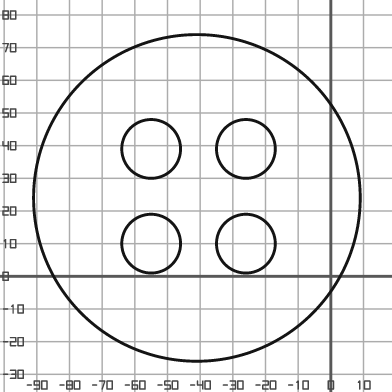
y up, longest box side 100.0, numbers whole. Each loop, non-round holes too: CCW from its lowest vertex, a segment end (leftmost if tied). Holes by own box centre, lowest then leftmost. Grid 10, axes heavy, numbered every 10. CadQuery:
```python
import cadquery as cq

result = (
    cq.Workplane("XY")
    .moveTo(-41.0, 24.0)
    .circle(50.0)
    .moveTo(-55.0, 10.0)
    .circle(9.0)
    .moveTo(-26.0, 10.0)
    .circle(9.0)
    .moveTo(-55.0, 39.0)
    .circle(9.0)
    .moveTo(-26.0, 39.0)
    .circle(9.0)
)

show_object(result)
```